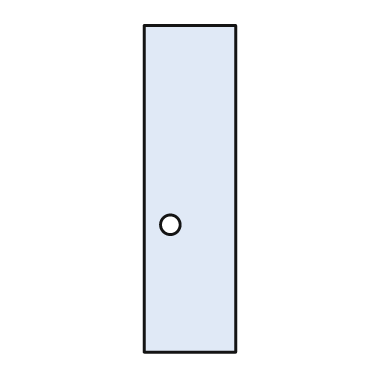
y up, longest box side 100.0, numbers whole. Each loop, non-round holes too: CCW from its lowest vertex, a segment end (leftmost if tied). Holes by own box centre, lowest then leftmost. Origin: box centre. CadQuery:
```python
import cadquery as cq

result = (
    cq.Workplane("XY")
    .moveTo(-14.0, -50.0)
    .lineTo(14.0, -50.0)
    .lineTo(14.0, 50.0)
    .lineTo(-14.0, 50.0)
    .close()
    .moveTo(-6.0, -11.0)
    .circle(3.0)
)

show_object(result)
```